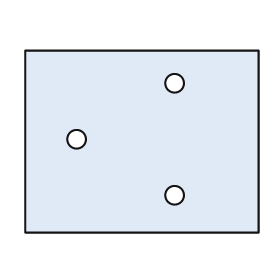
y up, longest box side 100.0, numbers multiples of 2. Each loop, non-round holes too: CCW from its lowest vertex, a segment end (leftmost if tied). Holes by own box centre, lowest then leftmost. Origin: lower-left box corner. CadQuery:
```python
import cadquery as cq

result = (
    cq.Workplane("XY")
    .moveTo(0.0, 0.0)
    .lineTo(100.0, 0.0)
    .lineTo(100.0, 78.0)
    .lineTo(0.0, 78.0)
    .close()
    .moveTo(64.0, 16.0)
    .circle(4.0)
    .moveTo(22.0, 40.0)
    .circle(4.0)
    .moveTo(64.0, 64.0)
    .circle(4.0)
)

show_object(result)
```